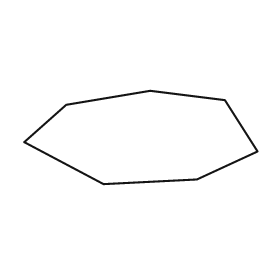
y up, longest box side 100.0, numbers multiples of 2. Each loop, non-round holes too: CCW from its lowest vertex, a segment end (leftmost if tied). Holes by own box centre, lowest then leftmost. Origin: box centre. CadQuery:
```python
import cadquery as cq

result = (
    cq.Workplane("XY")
    .moveTo(-16.0, -20.0)
    .lineTo(24.0, -18.0)
    .lineTo(50.0, -6.0)
    .lineTo(36.0, 16.0)
    .lineTo(4.0, 20.0)
    .lineTo(-32.0, 14.0)
    .lineTo(-50.0, -2.0)
    .close()
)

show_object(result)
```